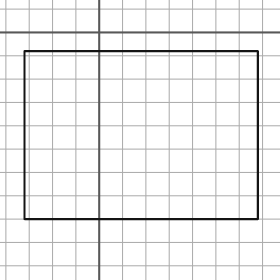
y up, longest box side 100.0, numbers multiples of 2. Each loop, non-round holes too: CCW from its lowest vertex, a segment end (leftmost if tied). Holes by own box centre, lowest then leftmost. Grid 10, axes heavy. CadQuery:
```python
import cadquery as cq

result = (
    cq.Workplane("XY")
    .moveTo(-32.0, -80.0)
    .lineTo(68.0, -80.0)
    .lineTo(68.0, -8.0)
    .lineTo(-32.0, -8.0)
    .close()
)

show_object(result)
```